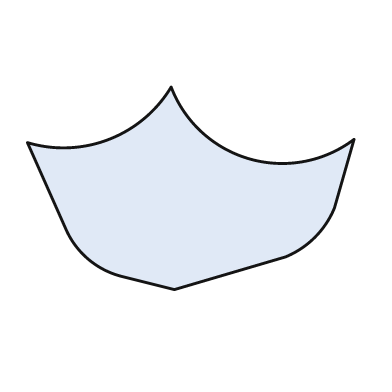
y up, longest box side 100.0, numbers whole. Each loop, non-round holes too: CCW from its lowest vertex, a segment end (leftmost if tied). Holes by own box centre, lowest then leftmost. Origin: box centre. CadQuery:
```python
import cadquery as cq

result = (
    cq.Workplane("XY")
    .moveTo(-5.0, -31.0)
    .lineTo(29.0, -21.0)
    .threePointArc((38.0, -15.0), (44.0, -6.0))
    .lineTo(50.0, 15.0)
    .threePointArc((18.0, 9.0), (-6.0, 31.0))
    .threePointArc((-25.0, 15.0), (-50.0, 14.0))
    .lineTo(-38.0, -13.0)
    .threePointArc((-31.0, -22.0), (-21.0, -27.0))
    .close()
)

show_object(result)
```